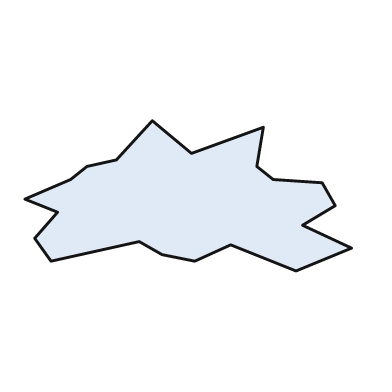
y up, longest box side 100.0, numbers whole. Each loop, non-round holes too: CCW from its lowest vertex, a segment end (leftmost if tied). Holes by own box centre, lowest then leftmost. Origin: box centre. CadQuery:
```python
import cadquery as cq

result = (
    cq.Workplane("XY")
    .moveTo(33.0, -23.0)
    .lineTo(50.0, -16.0)
    .lineTo(35.0, -9.0)
    .lineTo(45.0, -3.0)
    .lineTo(41.0, 4.0)
    .lineTo(26.0, 5.0)
    .lineTo(21.0, 9.0)
    .lineTo(23.0, 21.0)
    .lineTo(1.0, 13.0)
    .lineTo(-11.0, 23.0)
    .lineTo(-22.0, 11.0)
    .lineTo(-31.0, 9.0)
    .lineTo(-36.0, 5.0)
    .lineTo(-50.0, -1.0)
    .lineTo(-40.0, -5.0)
    .lineTo(-47.0, -13.0)
    .lineTo(-42.0, -20.0)
    .lineTo(-15.0, -14.0)
    .lineTo(-8.0, -18.0)
    .lineTo(2.0, -20.0)
    .lineTo(13.0, -15.0)
    .close()
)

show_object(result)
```